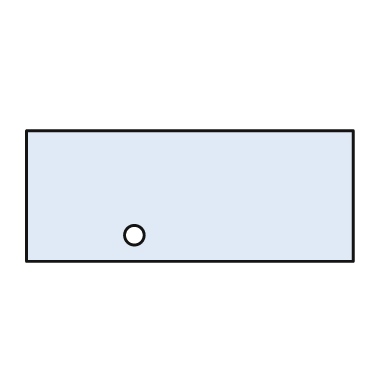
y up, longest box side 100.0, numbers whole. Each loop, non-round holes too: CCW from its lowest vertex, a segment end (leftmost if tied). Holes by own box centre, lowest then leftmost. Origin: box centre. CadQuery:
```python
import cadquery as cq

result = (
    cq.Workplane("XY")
    .moveTo(-50.0, -20.0)
    .lineTo(50.0, -20.0)
    .lineTo(50.0, 20.0)
    .lineTo(-50.0, 20.0)
    .close()
    .moveTo(-17.0, -12.0)
    .circle(3.0)
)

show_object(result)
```